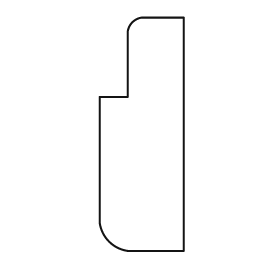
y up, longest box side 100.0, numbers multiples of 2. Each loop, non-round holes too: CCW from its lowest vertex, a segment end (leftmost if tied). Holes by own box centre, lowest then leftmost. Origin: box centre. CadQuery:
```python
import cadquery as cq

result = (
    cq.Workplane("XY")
    .moveTo(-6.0, -50.0)
    .lineTo(18.0, -50.0)
    .lineTo(18.0, 50.0)
    .lineTo(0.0, 50.0)
    .threePointArc((-4.0, 48.0), (-6.0, 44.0))
    .lineTo(-6.0, 16.0)
    .lineTo(-18.0, 16.0)
    .lineTo(-18.0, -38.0)
    .threePointArc((-14.0, -46.0), (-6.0, -50.0))
    .close()
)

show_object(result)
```